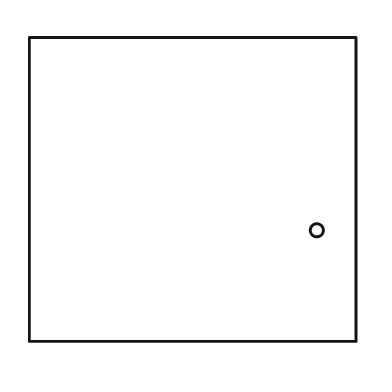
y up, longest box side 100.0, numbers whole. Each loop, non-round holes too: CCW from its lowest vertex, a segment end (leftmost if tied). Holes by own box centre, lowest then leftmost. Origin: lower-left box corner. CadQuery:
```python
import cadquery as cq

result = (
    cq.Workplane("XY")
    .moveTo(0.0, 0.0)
    .lineTo(100.0, 0.0)
    .lineTo(100.0, 93.0)
    .lineTo(0.0, 93.0)
    .close()
    .moveTo(88.0, 34.0)
    .circle(2.0)
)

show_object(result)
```